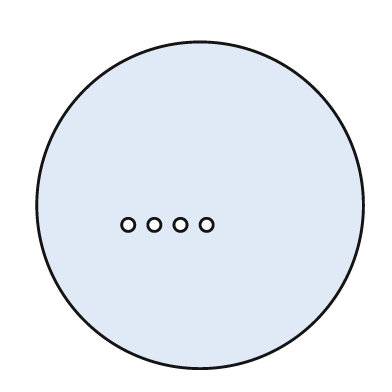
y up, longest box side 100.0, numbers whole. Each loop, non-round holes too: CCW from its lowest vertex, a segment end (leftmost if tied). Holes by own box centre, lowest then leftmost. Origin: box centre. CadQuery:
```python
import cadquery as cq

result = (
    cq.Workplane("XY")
    .moveTo(0.0, 0.0)
    .circle(50.0)
    .moveTo(-22.0, -6.0)
    .circle(2.0)
    .moveTo(-14.0, -6.0)
    .circle(2.0)
    .moveTo(-6.0, -6.0)
    .circle(2.0)
    .moveTo(2.0, -6.0)
    .circle(2.0)
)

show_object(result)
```